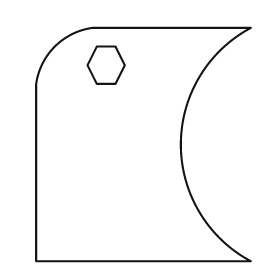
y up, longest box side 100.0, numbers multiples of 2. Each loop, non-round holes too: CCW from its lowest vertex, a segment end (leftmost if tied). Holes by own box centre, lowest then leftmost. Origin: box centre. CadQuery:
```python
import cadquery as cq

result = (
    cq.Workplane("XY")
    .moveTo(-46.0, -50.0)
    .lineTo(46.0, -50.0)
    .threePointArc((16.0, 0.0), (46.0, 50.0))
    .lineTo(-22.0, 50.0)
    .threePointArc((-38.0, 42.0), (-46.0, 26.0))
    .close()
    .moveTo(-20.0, 26.0)
    .lineTo(-12.0, 26.0)
    .lineTo(-8.0, 34.0)
    .lineTo(-12.0, 42.0)
    .lineTo(-20.0, 42.0)
    .lineTo(-24.0, 34.0)
    .close()
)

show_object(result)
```